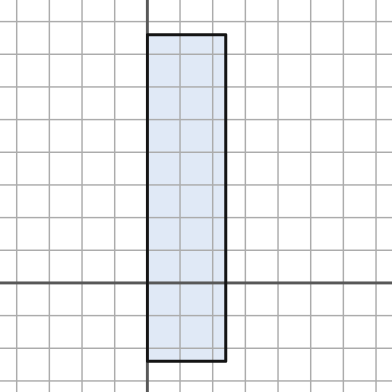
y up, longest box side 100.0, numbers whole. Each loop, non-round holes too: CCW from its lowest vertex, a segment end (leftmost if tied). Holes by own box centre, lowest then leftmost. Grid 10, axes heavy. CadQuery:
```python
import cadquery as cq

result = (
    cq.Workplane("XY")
    .moveTo(0.0, -24.0)
    .lineTo(24.0, -24.0)
    .lineTo(24.0, 76.0)
    .lineTo(0.0, 76.0)
    .close()
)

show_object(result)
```